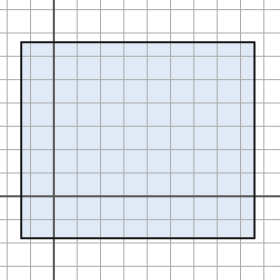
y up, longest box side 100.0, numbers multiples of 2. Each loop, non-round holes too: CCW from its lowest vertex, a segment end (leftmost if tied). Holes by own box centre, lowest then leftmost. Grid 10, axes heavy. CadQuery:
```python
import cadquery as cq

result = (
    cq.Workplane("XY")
    .moveTo(-14.0, -18.0)
    .lineTo(86.0, -18.0)
    .lineTo(86.0, 66.0)
    .lineTo(-14.0, 66.0)
    .close()
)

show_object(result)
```